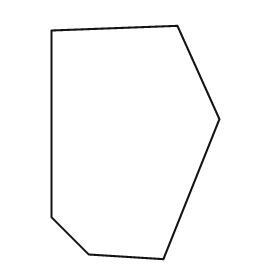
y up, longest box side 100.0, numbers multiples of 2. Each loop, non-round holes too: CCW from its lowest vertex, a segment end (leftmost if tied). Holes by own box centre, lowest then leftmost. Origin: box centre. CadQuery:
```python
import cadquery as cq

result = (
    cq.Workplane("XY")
    .moveTo(12.0, -50.0)
    .lineTo(36.0, 10.0)
    .lineTo(18.0, 50.0)
    .lineTo(-36.0, 48.0)
    .lineTo(-36.0, -32.0)
    .lineTo(-20.0, -48.0)
    .close()
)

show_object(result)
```